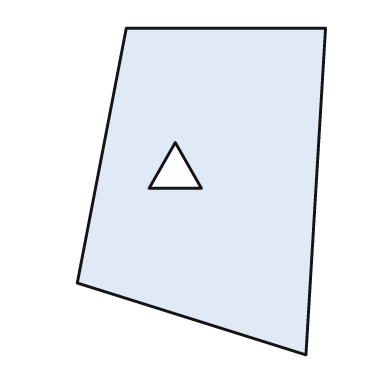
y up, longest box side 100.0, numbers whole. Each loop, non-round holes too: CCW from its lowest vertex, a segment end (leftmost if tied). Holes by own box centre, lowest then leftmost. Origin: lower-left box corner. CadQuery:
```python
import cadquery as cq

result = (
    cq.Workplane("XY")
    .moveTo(70.0, 0.0)
    .lineTo(76.0, 100.0)
    .lineTo(15.0, 100.0)
    .lineTo(0.0, 22.0)
    .close()
    .moveTo(22.0, 51.0)
    .lineTo(38.0, 51.0)
    .lineTo(30.0, 65.0)
    .close()
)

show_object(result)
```